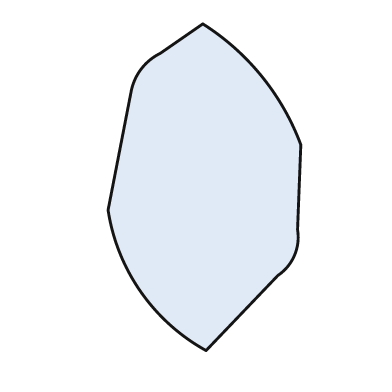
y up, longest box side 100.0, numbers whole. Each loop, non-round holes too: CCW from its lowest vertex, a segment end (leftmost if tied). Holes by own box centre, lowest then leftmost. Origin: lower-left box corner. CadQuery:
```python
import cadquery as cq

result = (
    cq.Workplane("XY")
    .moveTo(30.0, 0.0)
    .lineTo(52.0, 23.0)
    .threePointArc((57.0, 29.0), (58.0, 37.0))
    .lineTo(59.0, 63.0)
    .threePointArc((47.0, 84.0), (29.0, 100.0))
    .lineTo(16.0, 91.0)
    .threePointArc((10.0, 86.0), (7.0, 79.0))
    .lineTo(0.0, 43.0)
    .threePointArc((10.0, 18.0), (30.0, 0.0))
    .close()
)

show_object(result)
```